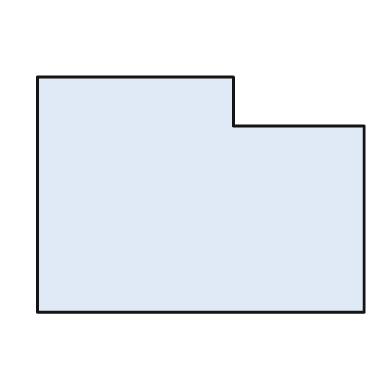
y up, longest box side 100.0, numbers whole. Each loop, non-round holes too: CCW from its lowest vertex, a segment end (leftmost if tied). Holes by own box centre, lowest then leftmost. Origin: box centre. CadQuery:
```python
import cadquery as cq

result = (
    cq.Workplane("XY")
    .moveTo(-50.0, -36.0)
    .lineTo(50.0, -36.0)
    .lineTo(50.0, 21.0)
    .lineTo(10.0, 21.0)
    .lineTo(10.0, 36.0)
    .lineTo(-50.0, 36.0)
    .close()
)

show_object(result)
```